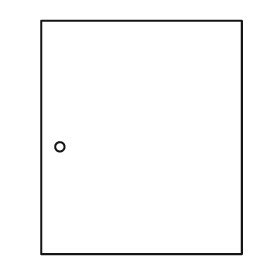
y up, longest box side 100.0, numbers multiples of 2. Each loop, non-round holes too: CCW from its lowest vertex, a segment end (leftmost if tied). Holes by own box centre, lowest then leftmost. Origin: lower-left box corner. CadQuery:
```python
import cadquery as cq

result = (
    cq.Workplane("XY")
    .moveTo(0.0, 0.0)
    .lineTo(86.0, 0.0)
    .lineTo(86.0, 100.0)
    .lineTo(0.0, 100.0)
    .close()
    .moveTo(8.0, 46.0)
    .circle(2.0)
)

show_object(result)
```